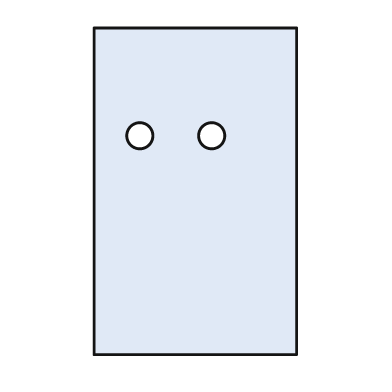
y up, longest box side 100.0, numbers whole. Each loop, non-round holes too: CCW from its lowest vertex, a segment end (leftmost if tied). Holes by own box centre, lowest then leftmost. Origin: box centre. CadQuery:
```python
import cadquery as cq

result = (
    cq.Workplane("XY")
    .moveTo(-31.0, -50.0)
    .lineTo(31.0, -50.0)
    .lineTo(31.0, 50.0)
    .lineTo(-31.0, 50.0)
    .close()
    .moveTo(-17.0, 17.0)
    .circle(4.0)
    .moveTo(5.0, 17.0)
    .circle(4.0)
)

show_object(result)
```